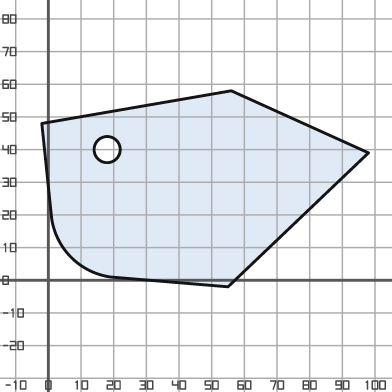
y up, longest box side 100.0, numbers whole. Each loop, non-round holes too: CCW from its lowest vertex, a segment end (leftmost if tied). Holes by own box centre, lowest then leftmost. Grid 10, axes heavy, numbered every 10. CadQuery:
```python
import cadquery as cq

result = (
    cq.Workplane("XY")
    .moveTo(55.0, -2.0)
    .lineTo(98.0, 39.0)
    .lineTo(56.0, 58.0)
    .lineTo(-2.0, 48.0)
    .lineTo(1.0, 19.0)
    .threePointArc((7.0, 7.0), (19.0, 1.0))
    .close()
    .moveTo(18.0, 40.0)
    .circle(4.0)
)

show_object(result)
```